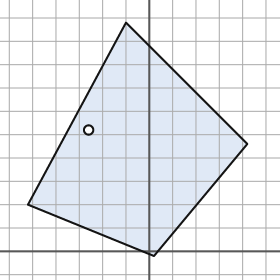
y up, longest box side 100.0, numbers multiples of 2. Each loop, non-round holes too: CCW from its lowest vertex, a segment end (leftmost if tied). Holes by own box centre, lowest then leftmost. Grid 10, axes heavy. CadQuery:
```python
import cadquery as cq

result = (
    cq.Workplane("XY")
    .moveTo(2.0, -2.0)
    .lineTo(42.0, 46.0)
    .lineTo(-10.0, 98.0)
    .lineTo(-52.0, 20.0)
    .close()
    .moveTo(-26.0, 52.0)
    .circle(2.0)
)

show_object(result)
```